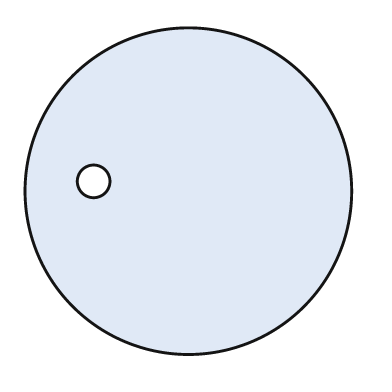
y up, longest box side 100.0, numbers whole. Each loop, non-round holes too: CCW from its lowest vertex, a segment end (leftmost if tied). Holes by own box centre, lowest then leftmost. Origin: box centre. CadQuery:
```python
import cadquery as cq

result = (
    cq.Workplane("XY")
    .moveTo(0.0, 0.0)
    .circle(50.0)
    .moveTo(-29.0, 3.0)
    .circle(5.0)
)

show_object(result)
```